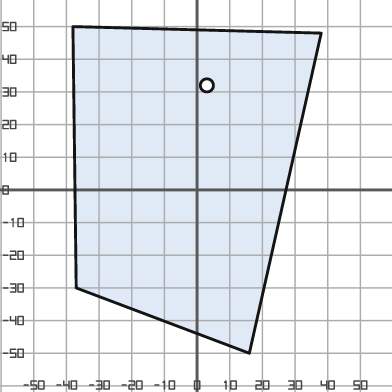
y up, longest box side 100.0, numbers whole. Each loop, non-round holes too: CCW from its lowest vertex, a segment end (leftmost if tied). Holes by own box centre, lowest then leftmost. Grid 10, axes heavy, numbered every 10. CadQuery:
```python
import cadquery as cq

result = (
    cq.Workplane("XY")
    .moveTo(16.0, -50.0)
    .lineTo(38.0, 48.0)
    .lineTo(-38.0, 50.0)
    .lineTo(-37.0, -30.0)
    .close()
    .moveTo(3.0, 32.0)
    .circle(2.0)
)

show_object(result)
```